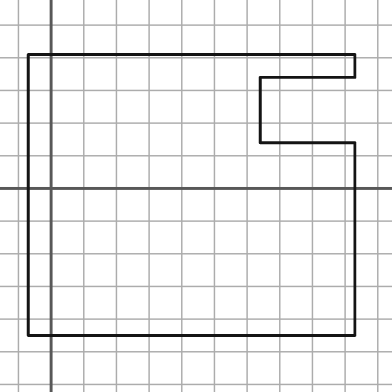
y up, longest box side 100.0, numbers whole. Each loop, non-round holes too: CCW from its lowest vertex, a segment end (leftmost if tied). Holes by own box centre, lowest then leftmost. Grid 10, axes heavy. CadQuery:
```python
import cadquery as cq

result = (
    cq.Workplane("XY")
    .moveTo(-7.0, -45.0)
    .lineTo(93.0, -45.0)
    .lineTo(93.0, 14.0)
    .lineTo(64.0, 14.0)
    .lineTo(64.0, 34.0)
    .lineTo(93.0, 34.0)
    .lineTo(93.0, 41.0)
    .lineTo(-7.0, 41.0)
    .close()
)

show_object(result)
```